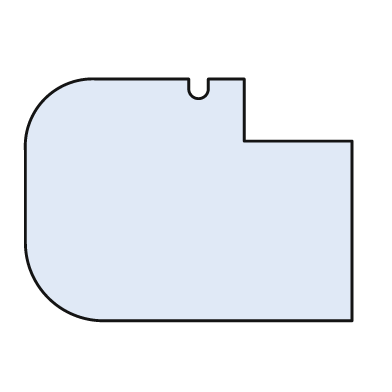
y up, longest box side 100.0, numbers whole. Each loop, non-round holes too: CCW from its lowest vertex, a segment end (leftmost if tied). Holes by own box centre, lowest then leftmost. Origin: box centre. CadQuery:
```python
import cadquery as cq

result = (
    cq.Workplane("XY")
    .moveTo(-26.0, -37.0)
    .lineTo(50.0, -37.0)
    .lineTo(50.0, 18.0)
    .lineTo(17.0, 18.0)
    .lineTo(17.0, 37.0)
    .lineTo(6.0, 37.0)
    .lineTo(6.0, 34.0)
    .threePointArc((3.0, 31.0), (0.0, 34.0))
    .lineTo(0.0, 37.0)
    .lineTo(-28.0, 37.0)
    .threePointArc((-44.0, 31.0), (-50.0, 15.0))
    .lineTo(-50.0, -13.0)
    .threePointArc((-43.0, -30.0), (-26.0, -37.0))
    .close()
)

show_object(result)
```